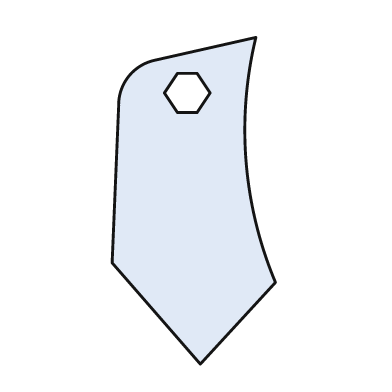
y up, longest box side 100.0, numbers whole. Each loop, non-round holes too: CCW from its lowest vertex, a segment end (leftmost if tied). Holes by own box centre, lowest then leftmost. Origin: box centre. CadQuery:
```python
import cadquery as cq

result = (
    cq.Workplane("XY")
    .moveTo(2.0, -50.0)
    .lineTo(25.0, -25.0)
    .threePointArc((16.0, 12.0), (19.0, 50.0))
    .lineTo(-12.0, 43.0)
    .threePointArc((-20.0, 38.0), (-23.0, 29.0))
    .lineTo(-25.0, -19.0)
    .close()
    .moveTo(-5.0, 27.0)
    .lineTo(1.0, 27.0)
    .lineTo(5.0, 33.0)
    .lineTo(1.0, 39.0)
    .lineTo(-5.0, 39.0)
    .lineTo(-9.0, 33.0)
    .close()
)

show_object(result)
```